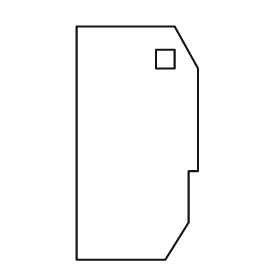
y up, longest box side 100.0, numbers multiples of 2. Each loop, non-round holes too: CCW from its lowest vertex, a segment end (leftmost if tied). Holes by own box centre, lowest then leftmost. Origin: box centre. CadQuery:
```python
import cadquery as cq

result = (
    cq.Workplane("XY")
    .moveTo(-26.0, -50.0)
    .lineTo(12.0, -50.0)
    .lineTo(22.0, -34.0)
    .lineTo(22.0, -12.0)
    .lineTo(26.0, -12.0)
    .lineTo(26.0, 32.0)
    .lineTo(16.0, 50.0)
    .lineTo(-26.0, 50.0)
    .close()
    .moveTo(8.0, 32.0)
    .lineTo(16.0, 32.0)
    .lineTo(16.0, 40.0)
    .lineTo(8.0, 40.0)
    .close()
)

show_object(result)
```